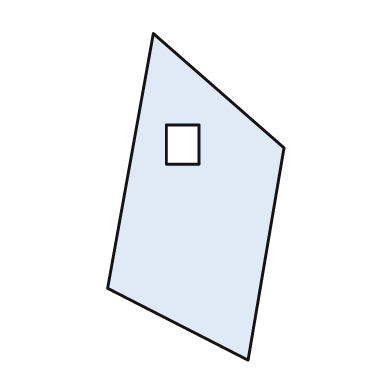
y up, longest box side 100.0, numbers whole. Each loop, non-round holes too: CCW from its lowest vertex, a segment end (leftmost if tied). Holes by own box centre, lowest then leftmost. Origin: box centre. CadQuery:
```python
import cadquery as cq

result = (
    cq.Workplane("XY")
    .moveTo(16.0, -50.0)
    .lineTo(27.0, 15.0)
    .lineTo(-13.0, 50.0)
    .lineTo(-27.0, -28.0)
    .close()
    .moveTo(-9.0, 10.0)
    .lineTo(1.0, 10.0)
    .lineTo(1.0, 22.0)
    .lineTo(-9.0, 22.0)
    .close()
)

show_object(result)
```